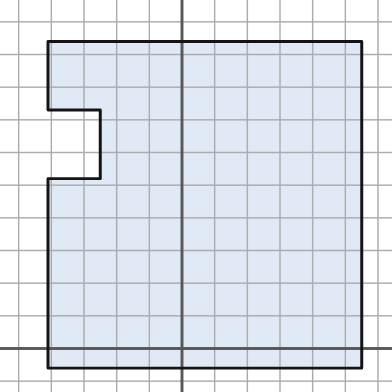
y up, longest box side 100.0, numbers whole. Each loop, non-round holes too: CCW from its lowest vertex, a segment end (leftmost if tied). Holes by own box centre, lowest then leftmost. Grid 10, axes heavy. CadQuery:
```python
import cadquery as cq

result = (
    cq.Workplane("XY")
    .moveTo(-41.0, -6.0)
    .lineTo(55.0, -6.0)
    .lineTo(55.0, 94.0)
    .lineTo(-41.0, 94.0)
    .lineTo(-41.0, 73.0)
    .lineTo(-25.0, 73.0)
    .lineTo(-25.0, 52.0)
    .lineTo(-41.0, 52.0)
    .close()
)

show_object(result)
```